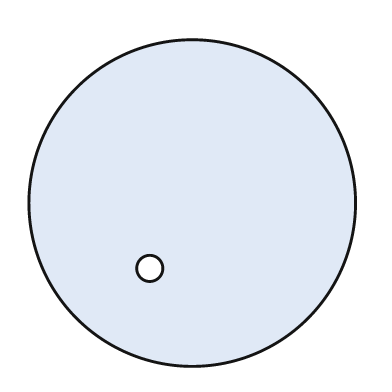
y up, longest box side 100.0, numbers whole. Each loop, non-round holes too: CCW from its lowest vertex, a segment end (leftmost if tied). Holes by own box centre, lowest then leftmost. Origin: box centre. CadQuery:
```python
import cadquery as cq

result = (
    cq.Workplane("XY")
    .moveTo(0.0, 0.0)
    .circle(50.0)
    .moveTo(-13.0, -20.0)
    .circle(4.0)
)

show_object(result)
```